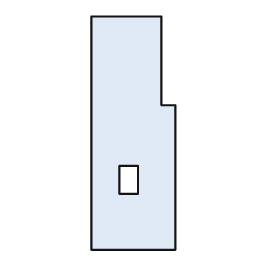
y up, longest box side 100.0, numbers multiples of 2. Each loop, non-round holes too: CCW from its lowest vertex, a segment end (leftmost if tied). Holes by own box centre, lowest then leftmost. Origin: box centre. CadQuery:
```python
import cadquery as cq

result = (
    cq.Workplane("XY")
    .moveTo(-18.0, -50.0)
    .lineTo(18.0, -50.0)
    .lineTo(18.0, 12.0)
    .lineTo(12.0, 12.0)
    .lineTo(12.0, 50.0)
    .lineTo(-18.0, 50.0)
    .close()
    .moveTo(-6.0, -26.0)
    .lineTo(2.0, -26.0)
    .lineTo(2.0, -14.0)
    .lineTo(-6.0, -14.0)
    .close()
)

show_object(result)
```